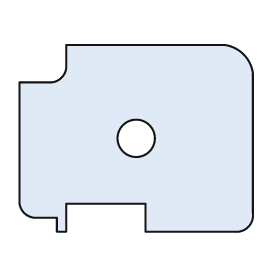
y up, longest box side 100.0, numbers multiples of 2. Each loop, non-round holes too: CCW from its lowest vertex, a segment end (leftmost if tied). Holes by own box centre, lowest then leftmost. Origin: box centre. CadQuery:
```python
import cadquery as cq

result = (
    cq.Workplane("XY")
    .moveTo(-34.0, -40.0)
    .lineTo(-30.0, -40.0)
    .lineTo(-30.0, -28.0)
    .lineTo(4.0, -28.0)
    .lineTo(4.0, -40.0)
    .lineTo(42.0, -40.0)
    .threePointArc((48.0, -38.0), (50.0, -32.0))
    .lineTo(50.0, 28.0)
    .threePointArc((46.0, 36.0), (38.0, 40.0))
    .lineTo(-30.0, 40.0)
    .lineTo(-30.0, 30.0)
    .threePointArc((-32.0, 26.0), (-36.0, 24.0))
    .lineTo(-50.0, 24.0)
    .lineTo(-50.0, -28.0)
    .threePointArc((-48.0, -32.0), (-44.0, -34.0))
    .lineTo(-34.0, -34.0)
    .close()
    .moveTo(0.0, 0.0)
    .circle(8.0)
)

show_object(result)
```